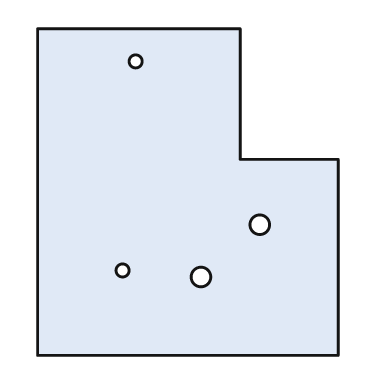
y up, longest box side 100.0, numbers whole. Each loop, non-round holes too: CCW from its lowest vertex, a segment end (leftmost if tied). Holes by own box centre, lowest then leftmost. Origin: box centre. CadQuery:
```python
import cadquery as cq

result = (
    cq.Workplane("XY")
    .moveTo(-46.0, -50.0)
    .lineTo(46.0, -50.0)
    .lineTo(46.0, 10.0)
    .lineTo(16.0, 10.0)
    .lineTo(16.0, 50.0)
    .lineTo(-46.0, 50.0)
    .close()
    .moveTo(4.0, -26.0)
    .circle(3.0)
    .moveTo(-20.0, -24.0)
    .circle(2.0)
    .moveTo(22.0, -10.0)
    .circle(3.0)
    .moveTo(-16.0, 40.0)
    .circle(2.0)
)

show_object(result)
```